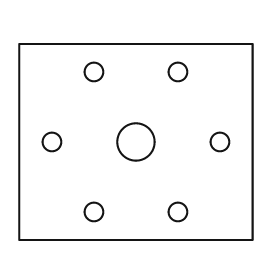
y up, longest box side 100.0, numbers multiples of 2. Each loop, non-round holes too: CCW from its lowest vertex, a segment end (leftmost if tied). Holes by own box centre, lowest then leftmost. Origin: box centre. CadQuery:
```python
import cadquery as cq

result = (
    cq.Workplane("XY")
    .moveTo(-50.0, -42.0)
    .lineTo(50.0, -42.0)
    .lineTo(50.0, 42.0)
    .lineTo(-50.0, 42.0)
    .close()
    .moveTo(-18.0, -30.0)
    .circle(4.0)
    .moveTo(18.0, -30.0)
    .circle(4.0)
    .moveTo(-36.0, 0.0)
    .circle(4.0)
    .moveTo(0.0, 0.0)
    .circle(8.0)
    .moveTo(36.0, 0.0)
    .circle(4.0)
    .moveTo(-18.0, 30.0)
    .circle(4.0)
    .moveTo(18.0, 30.0)
    .circle(4.0)
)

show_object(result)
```